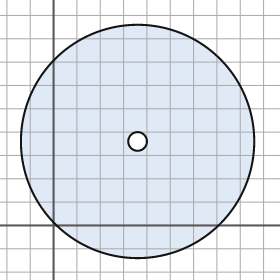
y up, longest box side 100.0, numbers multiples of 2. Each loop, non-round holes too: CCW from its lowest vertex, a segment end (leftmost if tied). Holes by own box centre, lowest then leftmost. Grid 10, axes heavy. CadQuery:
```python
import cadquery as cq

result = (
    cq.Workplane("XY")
    .moveTo(36.0, 36.0)
    .circle(50.0)
    .moveTo(36.0, 36.0)
    .circle(4.0)
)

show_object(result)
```